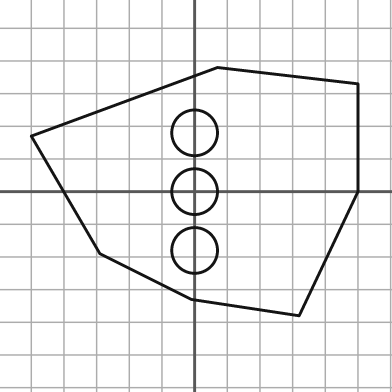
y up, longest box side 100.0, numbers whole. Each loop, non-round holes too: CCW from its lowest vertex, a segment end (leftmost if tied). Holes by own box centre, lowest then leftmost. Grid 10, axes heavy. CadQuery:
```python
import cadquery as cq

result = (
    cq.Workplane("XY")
    .moveTo(32.0, -38.0)
    .lineTo(50.0, 0.0)
    .lineTo(50.0, 33.0)
    .lineTo(7.0, 38.0)
    .lineTo(-50.0, 17.0)
    .lineTo(-29.0, -19.0)
    .lineTo(-1.0, -33.0)
    .close()
    .moveTo(0.0, -18.0)
    .circle(7.0)
    .moveTo(0.0, 0.0)
    .circle(7.0)
    .moveTo(0.0, 18.0)
    .circle(7.0)
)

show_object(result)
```